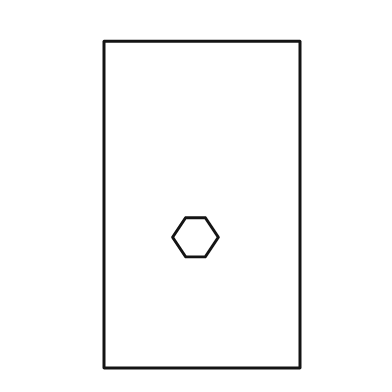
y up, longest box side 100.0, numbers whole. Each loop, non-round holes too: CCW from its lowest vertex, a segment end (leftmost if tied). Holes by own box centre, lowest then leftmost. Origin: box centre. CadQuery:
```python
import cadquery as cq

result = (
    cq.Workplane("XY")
    .moveTo(-30.0, -50.0)
    .lineTo(30.0, -50.0)
    .lineTo(30.0, 50.0)
    .lineTo(-30.0, 50.0)
    .close()
    .moveTo(-5.0, -16.0)
    .lineTo(1.0, -16.0)
    .lineTo(5.0, -10.0)
    .lineTo(1.0, -4.0)
    .lineTo(-5.0, -4.0)
    .lineTo(-9.0, -10.0)
    .close()
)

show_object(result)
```